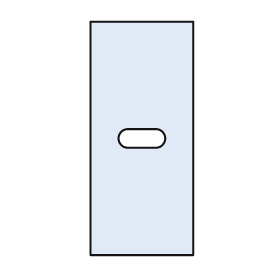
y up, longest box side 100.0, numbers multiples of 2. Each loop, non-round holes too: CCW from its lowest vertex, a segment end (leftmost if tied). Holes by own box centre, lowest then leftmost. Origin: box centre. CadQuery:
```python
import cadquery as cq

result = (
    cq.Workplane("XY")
    .moveTo(-22.0, -50.0)
    .lineTo(22.0, -50.0)
    .lineTo(22.0, 50.0)
    .lineTo(-22.0, 50.0)
    .close()
    .moveTo(-6.0, -4.0)
    .lineTo(6.0, -4.0)
    .threePointArc((10.0, 0.0), (6.0, 4.0))
    .lineTo(-6.0, 4.0)
    .threePointArc((-10.0, 0.0), (-6.0, -4.0))
    .close()
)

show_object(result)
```